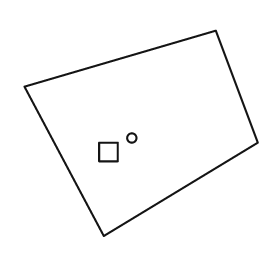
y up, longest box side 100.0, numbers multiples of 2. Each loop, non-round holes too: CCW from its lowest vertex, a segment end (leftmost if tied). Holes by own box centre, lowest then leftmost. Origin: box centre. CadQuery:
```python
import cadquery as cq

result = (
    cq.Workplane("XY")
    .moveTo(-16.0, -44.0)
    .lineTo(50.0, -4.0)
    .lineTo(32.0, 44.0)
    .lineTo(-50.0, 20.0)
    .close()
    .moveTo(-18.0, -12.0)
    .lineTo(-10.0, -12.0)
    .lineTo(-10.0, -4.0)
    .lineTo(-18.0, -4.0)
    .close()
    .moveTo(-4.0, -2.0)
    .circle(2.0)
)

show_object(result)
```